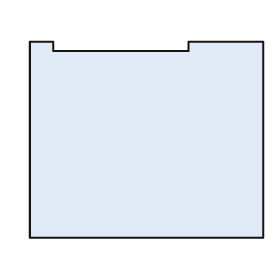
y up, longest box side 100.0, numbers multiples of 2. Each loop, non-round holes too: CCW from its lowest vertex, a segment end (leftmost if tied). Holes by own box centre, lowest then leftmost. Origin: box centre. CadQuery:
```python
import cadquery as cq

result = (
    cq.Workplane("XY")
    .moveTo(-50.0, -42.0)
    .lineTo(50.0, -42.0)
    .lineTo(50.0, 42.0)
    .lineTo(18.0, 42.0)
    .lineTo(18.0, 38.0)
    .lineTo(-40.0, 38.0)
    .lineTo(-40.0, 42.0)
    .lineTo(-50.0, 42.0)
    .close()
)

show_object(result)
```